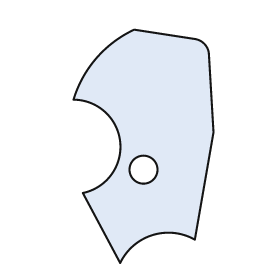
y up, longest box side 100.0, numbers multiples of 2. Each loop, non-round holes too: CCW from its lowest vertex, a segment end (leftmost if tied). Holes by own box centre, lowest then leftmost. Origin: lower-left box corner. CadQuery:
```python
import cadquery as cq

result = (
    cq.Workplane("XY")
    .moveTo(20.0, 0.0)
    .threePointArc((34.0, 12.0), (52.0, 10.0))
    .lineTo(60.0, 56.0)
    .lineTo(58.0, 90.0)
    .threePointArc((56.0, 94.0), (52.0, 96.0))
    .lineTo(26.0, 100.0)
    .threePointArc((10.0, 88.0), (0.0, 70.0))
    .threePointArc((20.0, 52.0), (4.0, 30.0))
    .close()
    .moveTo(30.0, 40.0)
    .circle(6.0)
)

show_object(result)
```